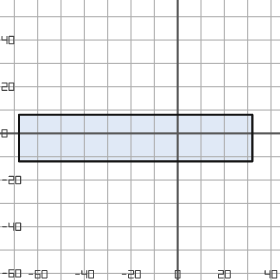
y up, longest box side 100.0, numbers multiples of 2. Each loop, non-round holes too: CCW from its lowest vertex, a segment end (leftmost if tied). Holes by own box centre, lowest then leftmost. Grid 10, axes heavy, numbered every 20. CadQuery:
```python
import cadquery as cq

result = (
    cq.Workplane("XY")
    .moveTo(-68.0, -12.0)
    .lineTo(32.0, -12.0)
    .lineTo(32.0, 8.0)
    .lineTo(-68.0, 8.0)
    .close()
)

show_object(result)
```